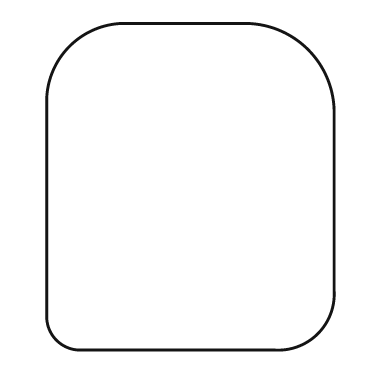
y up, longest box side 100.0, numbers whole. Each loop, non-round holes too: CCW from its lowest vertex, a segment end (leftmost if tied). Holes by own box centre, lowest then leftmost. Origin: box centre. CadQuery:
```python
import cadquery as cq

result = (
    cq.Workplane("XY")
    .moveTo(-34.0, -50.0)
    .lineTo(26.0, -50.0)
    .threePointArc((39.0, -45.0), (44.0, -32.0))
    .lineTo(44.0, 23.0)
    .threePointArc((36.0, 42.0), (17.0, 50.0))
    .lineTo(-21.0, 50.0)
    .threePointArc((-37.0, 43.0), (-44.0, 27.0))
    .lineTo(-44.0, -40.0)
    .threePointArc((-41.0, -47.0), (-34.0, -50.0))
    .close()
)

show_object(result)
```